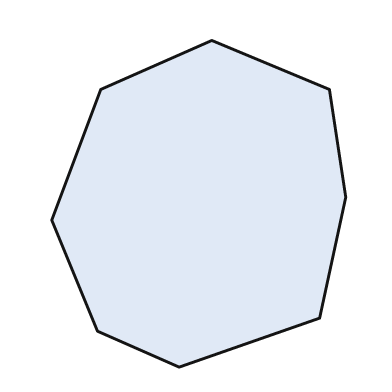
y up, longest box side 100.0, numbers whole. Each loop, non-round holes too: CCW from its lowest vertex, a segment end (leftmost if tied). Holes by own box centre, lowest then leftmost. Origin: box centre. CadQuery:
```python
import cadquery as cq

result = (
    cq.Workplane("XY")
    .moveTo(-6.0, -50.0)
    .lineTo(37.0, -35.0)
    .lineTo(45.0, 2.0)
    .lineTo(40.0, 35.0)
    .lineTo(4.0, 50.0)
    .lineTo(-30.0, 35.0)
    .lineTo(-45.0, -5.0)
    .lineTo(-31.0, -39.0)
    .close()
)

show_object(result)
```